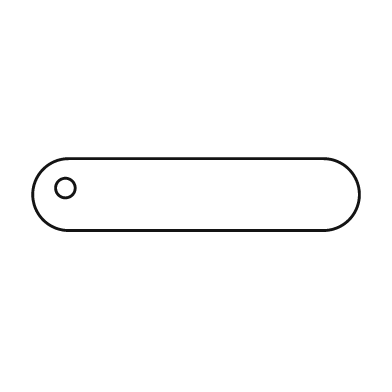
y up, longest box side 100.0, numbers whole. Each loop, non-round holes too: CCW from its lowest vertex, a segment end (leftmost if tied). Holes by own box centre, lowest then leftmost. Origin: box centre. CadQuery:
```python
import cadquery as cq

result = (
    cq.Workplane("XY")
    .moveTo(-39.0, -11.0)
    .lineTo(39.0, -11.0)
    .threePointArc((50.0, 0.0), (39.0, 11.0))
    .lineTo(-39.0, 11.0)
    .threePointArc((-50.0, 0.0), (-39.0, -11.0))
    .close()
    .moveTo(-40.0, 2.0)
    .circle(3.0)
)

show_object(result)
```